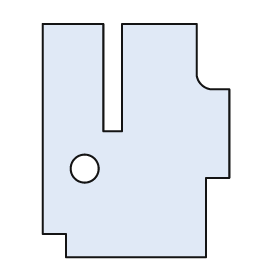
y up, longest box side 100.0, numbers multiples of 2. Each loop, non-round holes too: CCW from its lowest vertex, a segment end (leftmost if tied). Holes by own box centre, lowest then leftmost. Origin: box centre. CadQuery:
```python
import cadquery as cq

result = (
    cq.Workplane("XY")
    .moveTo(-30.0, -50.0)
    .lineTo(30.0, -50.0)
    .lineTo(30.0, -16.0)
    .lineTo(40.0, -16.0)
    .lineTo(40.0, 22.0)
    .lineTo(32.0, 22.0)
    .threePointArc((28.0, 24.0), (26.0, 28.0))
    .lineTo(26.0, 50.0)
    .lineTo(-6.0, 50.0)
    .lineTo(-6.0, 4.0)
    .lineTo(-14.0, 4.0)
    .lineTo(-14.0, 50.0)
    .lineTo(-40.0, 50.0)
    .lineTo(-40.0, -40.0)
    .lineTo(-30.0, -40.0)
    .close()
    .moveTo(-22.0, -12.0)
    .circle(6.0)
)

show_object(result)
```